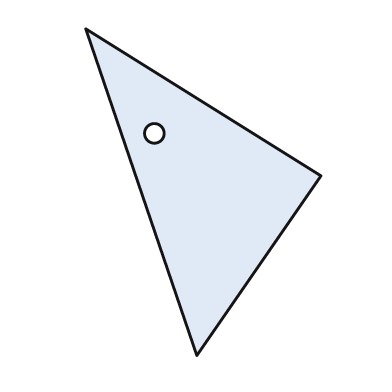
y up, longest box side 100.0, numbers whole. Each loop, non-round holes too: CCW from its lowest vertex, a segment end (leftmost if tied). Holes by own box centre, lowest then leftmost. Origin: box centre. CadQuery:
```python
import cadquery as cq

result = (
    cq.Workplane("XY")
    .moveTo(-2.0, -50.0)
    .lineTo(36.0, 5.0)
    .lineTo(-36.0, 50.0)
    .close()
    .moveTo(-15.0, 18.0)
    .circle(3.0)
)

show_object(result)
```